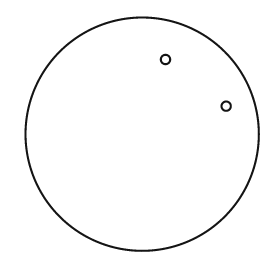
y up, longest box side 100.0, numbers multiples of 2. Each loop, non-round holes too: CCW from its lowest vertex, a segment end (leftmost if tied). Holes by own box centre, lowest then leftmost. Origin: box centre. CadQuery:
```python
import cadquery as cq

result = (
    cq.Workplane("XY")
    .moveTo(0.0, 0.0)
    .circle(50.0)
    .moveTo(36.0, 12.0)
    .circle(2.0)
    .moveTo(10.0, 32.0)
    .circle(2.0)
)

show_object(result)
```